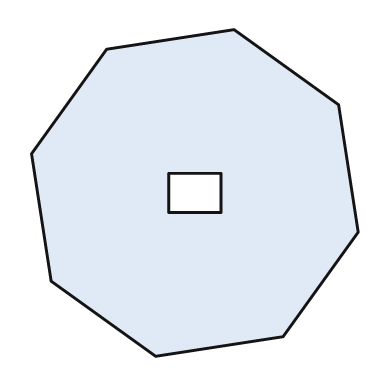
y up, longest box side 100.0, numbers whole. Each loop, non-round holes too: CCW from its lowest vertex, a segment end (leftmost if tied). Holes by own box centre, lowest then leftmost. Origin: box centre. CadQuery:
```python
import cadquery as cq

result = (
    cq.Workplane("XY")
    .moveTo(-12.0, -50.0)
    .lineTo(27.0, -44.0)
    .lineTo(50.0, -12.0)
    .lineTo(44.0, 27.0)
    .lineTo(12.0, 50.0)
    .lineTo(-27.0, 44.0)
    .lineTo(-50.0, 12.0)
    .lineTo(-44.0, -27.0)
    .close()
    .moveTo(-8.0, -6.0)
    .lineTo(8.0, -6.0)
    .lineTo(8.0, 6.0)
    .lineTo(-8.0, 6.0)
    .close()
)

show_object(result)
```